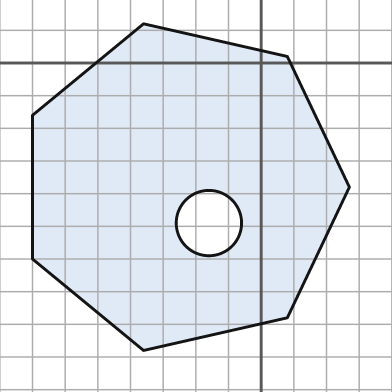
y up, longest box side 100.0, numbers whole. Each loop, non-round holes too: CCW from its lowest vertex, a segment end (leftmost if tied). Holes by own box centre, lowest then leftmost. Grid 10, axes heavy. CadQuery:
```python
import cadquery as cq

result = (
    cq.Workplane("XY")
    .moveTo(-36.0, -88.0)
    .lineTo(8.0, -78.0)
    .lineTo(27.0, -38.0)
    .lineTo(8.0, 2.0)
    .lineTo(-36.0, 12.0)
    .lineTo(-70.0, -16.0)
    .lineTo(-70.0, -60.0)
    .close()
    .moveTo(-16.0, -49.0)
    .circle(10.0)
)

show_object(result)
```